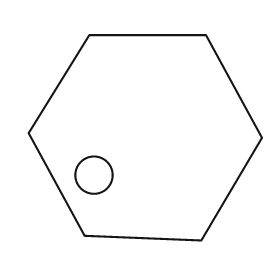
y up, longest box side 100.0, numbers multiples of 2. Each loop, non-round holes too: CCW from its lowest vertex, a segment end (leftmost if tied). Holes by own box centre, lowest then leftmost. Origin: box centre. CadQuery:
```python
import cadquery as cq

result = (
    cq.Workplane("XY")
    .moveTo(24.0, -44.0)
    .lineTo(50.0, 0.0)
    .lineTo(26.0, 44.0)
    .lineTo(-24.0, 44.0)
    .lineTo(-50.0, 2.0)
    .lineTo(-26.0, -42.0)
    .close()
    .moveTo(-22.0, -16.0)
    .circle(8.0)
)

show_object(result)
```